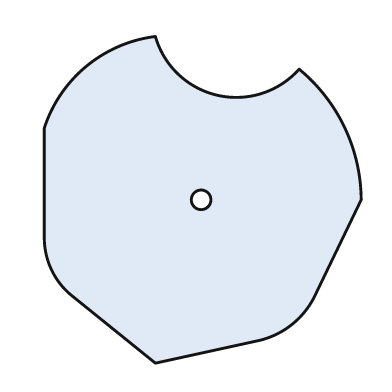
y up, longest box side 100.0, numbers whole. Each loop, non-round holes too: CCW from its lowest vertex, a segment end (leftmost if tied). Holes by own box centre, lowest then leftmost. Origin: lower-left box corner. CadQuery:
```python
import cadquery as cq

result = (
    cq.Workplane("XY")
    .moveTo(34.0, 0.0)
    .lineTo(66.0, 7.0)
    .threePointArc((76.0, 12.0), (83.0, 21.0))
    .lineTo(97.0, 50.0)
    .threePointArc((92.0, 72.0), (78.0, 90.0))
    .threePointArc((53.0, 82.0), (34.0, 100.0))
    .threePointArc((13.0, 91.0), (0.0, 72.0))
    .lineTo(0.0, 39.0)
    .threePointArc((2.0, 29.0), (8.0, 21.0))
    .close()
    .moveTo(48.0, 50.0)
    .circle(3.0)
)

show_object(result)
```